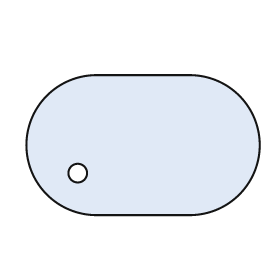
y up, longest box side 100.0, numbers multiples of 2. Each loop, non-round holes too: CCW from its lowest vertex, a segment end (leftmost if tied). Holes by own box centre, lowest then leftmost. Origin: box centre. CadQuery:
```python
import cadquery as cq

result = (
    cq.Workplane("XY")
    .moveTo(-20.0, -30.0)
    .lineTo(20.0, -30.0)
    .threePointArc((50.0, 0.0), (20.0, 30.0))
    .lineTo(-20.0, 30.0)
    .threePointArc((-50.0, 0.0), (-20.0, -30.0))
    .close()
    .moveTo(-28.0, -12.0)
    .circle(4.0)
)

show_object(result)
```